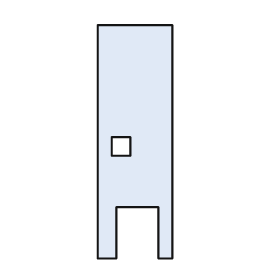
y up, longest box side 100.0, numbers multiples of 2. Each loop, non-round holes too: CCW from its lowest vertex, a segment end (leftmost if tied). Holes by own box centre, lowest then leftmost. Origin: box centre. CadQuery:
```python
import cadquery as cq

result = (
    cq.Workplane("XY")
    .moveTo(-16.0, -50.0)
    .lineTo(-8.0, -50.0)
    .lineTo(-8.0, -28.0)
    .lineTo(10.0, -28.0)
    .lineTo(10.0, -50.0)
    .lineTo(16.0, -50.0)
    .lineTo(16.0, 50.0)
    .lineTo(-16.0, 50.0)
    .close()
    .moveTo(-10.0, -6.0)
    .lineTo(-2.0, -6.0)
    .lineTo(-2.0, 2.0)
    .lineTo(-10.0, 2.0)
    .close()
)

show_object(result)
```